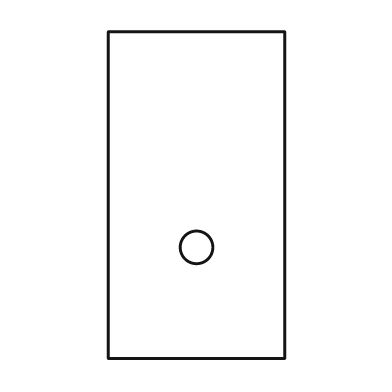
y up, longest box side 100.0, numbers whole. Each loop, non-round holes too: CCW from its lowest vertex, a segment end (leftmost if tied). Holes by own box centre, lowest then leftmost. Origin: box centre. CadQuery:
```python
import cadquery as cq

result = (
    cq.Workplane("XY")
    .moveTo(-27.0, -50.0)
    .lineTo(27.0, -50.0)
    .lineTo(27.0, 50.0)
    .lineTo(-27.0, 50.0)
    .close()
    .moveTo(0.0, -16.0)
    .circle(5.0)
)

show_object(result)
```